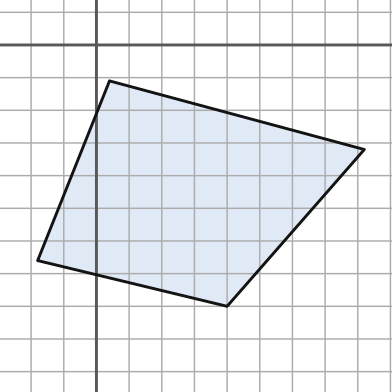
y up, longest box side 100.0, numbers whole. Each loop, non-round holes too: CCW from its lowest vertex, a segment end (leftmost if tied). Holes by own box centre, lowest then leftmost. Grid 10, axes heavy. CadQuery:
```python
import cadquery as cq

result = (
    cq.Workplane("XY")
    .moveTo(40.0, -80.0)
    .lineTo(82.0, -32.0)
    .lineTo(4.0, -11.0)
    .lineTo(-18.0, -66.0)
    .close()
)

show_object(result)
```